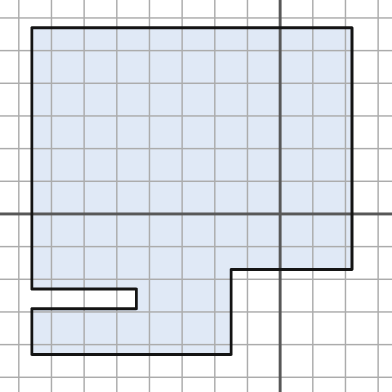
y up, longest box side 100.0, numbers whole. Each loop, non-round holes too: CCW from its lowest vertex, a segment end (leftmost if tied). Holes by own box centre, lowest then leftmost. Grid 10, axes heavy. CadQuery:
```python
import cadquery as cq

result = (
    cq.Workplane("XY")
    .moveTo(-76.0, -43.0)
    .lineTo(-15.0, -43.0)
    .lineTo(-15.0, -17.0)
    .lineTo(22.0, -17.0)
    .lineTo(22.0, 57.0)
    .lineTo(-76.0, 57.0)
    .lineTo(-76.0, -23.0)
    .lineTo(-44.0, -23.0)
    .lineTo(-44.0, -29.0)
    .lineTo(-76.0, -29.0)
    .close()
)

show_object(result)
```